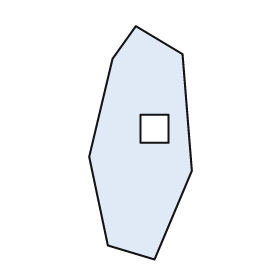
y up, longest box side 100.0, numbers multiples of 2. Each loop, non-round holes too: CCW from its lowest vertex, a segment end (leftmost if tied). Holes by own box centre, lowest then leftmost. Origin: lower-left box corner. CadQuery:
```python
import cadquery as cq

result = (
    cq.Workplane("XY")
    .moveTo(28.0, 0.0)
    .lineTo(44.0, 38.0)
    .lineTo(40.0, 88.0)
    .lineTo(20.0, 100.0)
    .lineTo(10.0, 86.0)
    .lineTo(0.0, 44.0)
    .lineTo(8.0, 6.0)
    .close()
    .moveTo(22.0, 50.0)
    .lineTo(34.0, 50.0)
    .lineTo(34.0, 62.0)
    .lineTo(22.0, 62.0)
    .close()
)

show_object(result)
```